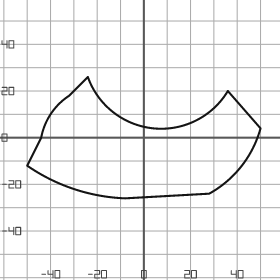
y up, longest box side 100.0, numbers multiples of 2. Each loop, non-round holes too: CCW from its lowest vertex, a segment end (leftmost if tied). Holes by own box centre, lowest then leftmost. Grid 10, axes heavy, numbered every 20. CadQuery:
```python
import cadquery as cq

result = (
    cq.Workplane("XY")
    .moveTo(-8.0, -26.0)
    .lineTo(28.0, -24.0)
    .threePointArc((42.0, -12.0), (50.0, 4.0))
    .lineTo(36.0, 20.0)
    .threePointArc((4.0, 4.0), (-24.0, 26.0))
    .lineTo(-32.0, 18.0)
    .threePointArc((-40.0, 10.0), (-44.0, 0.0))
    .lineTo(-50.0, -12.0)
    .threePointArc((-30.0, -22.0), (-8.0, -26.0))
    .close()
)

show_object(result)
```